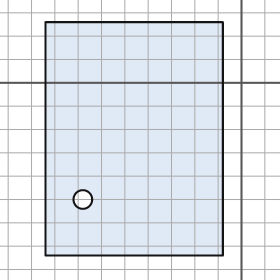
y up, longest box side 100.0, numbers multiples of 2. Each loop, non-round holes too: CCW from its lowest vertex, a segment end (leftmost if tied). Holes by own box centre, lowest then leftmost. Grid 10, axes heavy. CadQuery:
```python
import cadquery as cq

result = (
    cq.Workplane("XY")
    .moveTo(-84.0, -74.0)
    .lineTo(-8.0, -74.0)
    .lineTo(-8.0, 26.0)
    .lineTo(-84.0, 26.0)
    .close()
    .moveTo(-68.0, -50.0)
    .circle(4.0)
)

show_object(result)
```